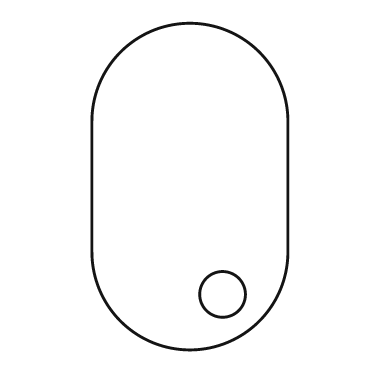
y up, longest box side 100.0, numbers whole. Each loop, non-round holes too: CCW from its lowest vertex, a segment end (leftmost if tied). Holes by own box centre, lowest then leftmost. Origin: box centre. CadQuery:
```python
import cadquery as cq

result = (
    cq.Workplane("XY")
    .moveTo(-30.0, -20.0)
    .threePointArc((0.0, -50.0), (30.0, -20.0))
    .lineTo(30.0, 20.0)
    .threePointArc((0.0, 50.0), (-30.0, 20.0))
    .close()
    .moveTo(10.0, -33.0)
    .circle(7.0)
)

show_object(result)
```